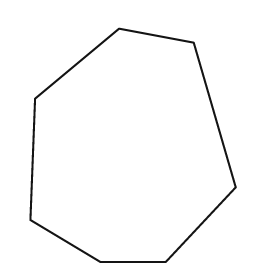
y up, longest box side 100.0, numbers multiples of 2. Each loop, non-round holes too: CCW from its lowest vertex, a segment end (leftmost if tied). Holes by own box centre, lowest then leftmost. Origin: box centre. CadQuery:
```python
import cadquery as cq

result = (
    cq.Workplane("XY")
    .moveTo(-14.0, -50.0)
    .lineTo(14.0, -50.0)
    .lineTo(44.0, -18.0)
    .lineTo(26.0, 44.0)
    .lineTo(-6.0, 50.0)
    .lineTo(-42.0, 20.0)
    .lineTo(-44.0, -32.0)
    .close()
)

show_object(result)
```